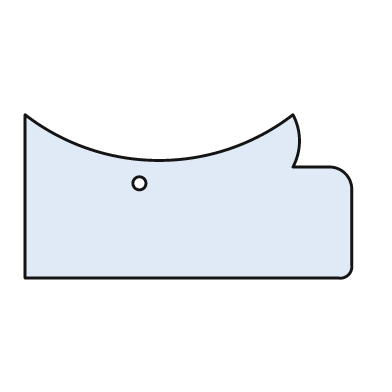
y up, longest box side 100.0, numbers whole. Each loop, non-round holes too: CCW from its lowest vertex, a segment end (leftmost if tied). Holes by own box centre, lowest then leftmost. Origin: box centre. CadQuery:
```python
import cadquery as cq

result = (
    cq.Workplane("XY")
    .moveTo(-50.0, -25.0)
    .lineTo(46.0, -25.0)
    .threePointArc((49.0, -24.0), (50.0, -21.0))
    .lineTo(50.0, 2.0)
    .threePointArc((48.0, 7.0), (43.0, 9.0))
    .lineTo(32.0, 9.0)
    .threePointArc((34.0, 17.0), (32.0, 25.0))
    .threePointArc((-9.0, 11.0), (-50.0, 25.0))
    .close()
    .moveTo(-15.0, 4.0)
    .circle(2.0)
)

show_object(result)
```